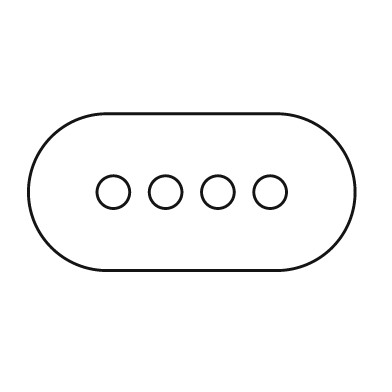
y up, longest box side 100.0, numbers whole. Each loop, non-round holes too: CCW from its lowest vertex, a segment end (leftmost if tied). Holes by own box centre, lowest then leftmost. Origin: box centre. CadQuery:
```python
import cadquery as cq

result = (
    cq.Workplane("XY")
    .moveTo(-26.0, -24.0)
    .lineTo(26.0, -24.0)
    .threePointArc((50.0, 0.0), (26.0, 24.0))
    .lineTo(-26.0, 24.0)
    .threePointArc((-50.0, 0.0), (-26.0, -24.0))
    .close()
    .moveTo(-24.0, 0.0)
    .circle(5.0)
    .moveTo(-8.0, 0.0)
    .circle(5.0)
    .moveTo(8.0, 0.0)
    .circle(5.0)
    .moveTo(24.0, 0.0)
    .circle(5.0)
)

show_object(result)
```